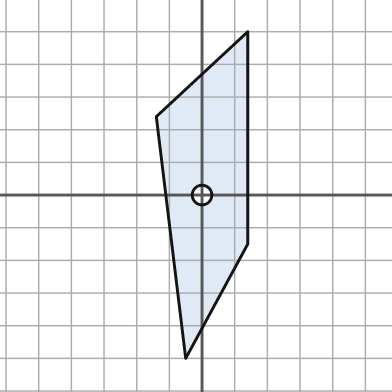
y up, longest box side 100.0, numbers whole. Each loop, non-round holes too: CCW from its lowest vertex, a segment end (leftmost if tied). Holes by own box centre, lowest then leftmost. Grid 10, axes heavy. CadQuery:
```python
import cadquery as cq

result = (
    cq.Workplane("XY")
    .moveTo(-5.0, -50.0)
    .lineTo(14.0, -15.0)
    .lineTo(14.0, 50.0)
    .lineTo(-14.0, 24.0)
    .close()
    .moveTo(0.0, 0.0)
    .circle(3.0)
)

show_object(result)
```